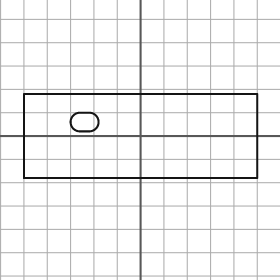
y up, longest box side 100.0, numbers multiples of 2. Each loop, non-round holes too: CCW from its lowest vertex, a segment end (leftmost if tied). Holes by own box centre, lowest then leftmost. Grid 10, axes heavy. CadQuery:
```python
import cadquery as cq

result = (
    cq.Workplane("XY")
    .moveTo(-50.0, -18.0)
    .lineTo(50.0, -18.0)
    .lineTo(50.0, 18.0)
    .lineTo(-50.0, 18.0)
    .close()
    .moveTo(-26.0, 2.0)
    .lineTo(-22.0, 2.0)
    .threePointArc((-18.0, 6.0), (-22.0, 10.0))
    .lineTo(-26.0, 10.0)
    .threePointArc((-30.0, 6.0), (-26.0, 2.0))
    .close()
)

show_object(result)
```